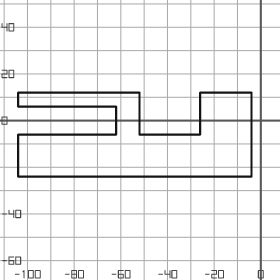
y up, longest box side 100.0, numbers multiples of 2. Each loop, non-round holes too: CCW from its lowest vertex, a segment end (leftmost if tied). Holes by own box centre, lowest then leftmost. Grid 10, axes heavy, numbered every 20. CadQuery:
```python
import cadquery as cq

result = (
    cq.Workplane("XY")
    .moveTo(-104.0, -24.0)
    .lineTo(-4.0, -24.0)
    .lineTo(-4.0, 12.0)
    .lineTo(-26.0, 12.0)
    .lineTo(-26.0, -6.0)
    .lineTo(-52.0, -6.0)
    .lineTo(-52.0, 12.0)
    .lineTo(-104.0, 12.0)
    .lineTo(-104.0, 6.0)
    .lineTo(-62.0, 6.0)
    .lineTo(-62.0, -6.0)
    .lineTo(-104.0, -6.0)
    .close()
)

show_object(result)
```